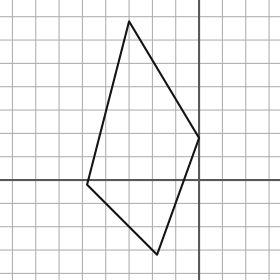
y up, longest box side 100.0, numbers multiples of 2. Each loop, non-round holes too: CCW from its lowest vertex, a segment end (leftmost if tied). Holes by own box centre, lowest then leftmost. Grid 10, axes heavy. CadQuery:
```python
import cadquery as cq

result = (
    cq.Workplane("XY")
    .moveTo(-18.0, -32.0)
    .lineTo(0.0, 18.0)
    .lineTo(-30.0, 68.0)
    .lineTo(-48.0, -2.0)
    .close()
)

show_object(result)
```